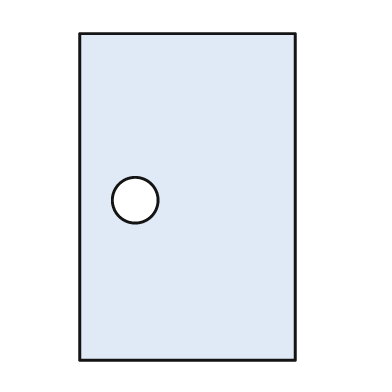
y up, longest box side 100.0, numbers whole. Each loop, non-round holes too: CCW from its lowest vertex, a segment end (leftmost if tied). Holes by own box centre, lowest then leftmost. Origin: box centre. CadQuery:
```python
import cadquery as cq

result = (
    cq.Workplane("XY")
    .moveTo(-33.0, -50.0)
    .lineTo(33.0, -50.0)
    .lineTo(33.0, 50.0)
    .lineTo(-33.0, 50.0)
    .close()
    .moveTo(-16.0, -1.0)
    .circle(7.0)
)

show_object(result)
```